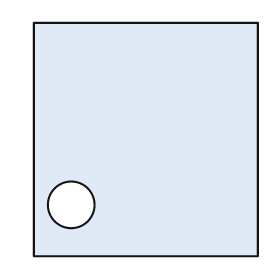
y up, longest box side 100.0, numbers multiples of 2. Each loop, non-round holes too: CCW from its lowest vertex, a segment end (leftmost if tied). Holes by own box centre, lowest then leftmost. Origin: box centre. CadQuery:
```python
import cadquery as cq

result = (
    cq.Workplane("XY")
    .moveTo(-48.0, -50.0)
    .lineTo(48.0, -50.0)
    .lineTo(48.0, 50.0)
    .lineTo(-48.0, 50.0)
    .close()
    .moveTo(-32.0, -28.0)
    .circle(10.0)
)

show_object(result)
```